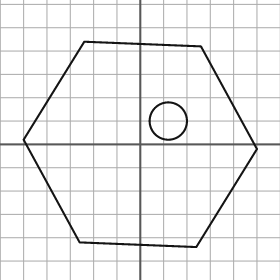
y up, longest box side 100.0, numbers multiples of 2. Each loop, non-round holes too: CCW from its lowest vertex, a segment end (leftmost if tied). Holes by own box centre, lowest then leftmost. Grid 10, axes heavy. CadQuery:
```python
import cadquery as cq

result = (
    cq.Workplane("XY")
    .moveTo(24.0, -44.0)
    .lineTo(50.0, -2.0)
    .lineTo(26.0, 42.0)
    .lineTo(-24.0, 44.0)
    .lineTo(-50.0, 2.0)
    .lineTo(-26.0, -42.0)
    .close()
    .moveTo(12.0, 10.0)
    .circle(8.0)
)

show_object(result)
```